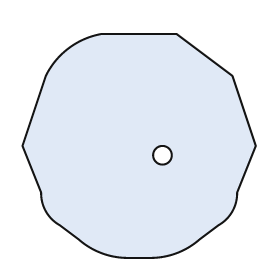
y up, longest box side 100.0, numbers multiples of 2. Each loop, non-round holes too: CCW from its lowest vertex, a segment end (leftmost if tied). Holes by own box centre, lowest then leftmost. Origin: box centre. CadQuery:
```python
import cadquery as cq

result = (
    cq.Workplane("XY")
    .moveTo(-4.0, -48.0)
    .lineTo(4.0, -48.0)
    .threePointArc((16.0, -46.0), (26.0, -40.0))
    .lineTo(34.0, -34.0)
    .threePointArc((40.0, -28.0), (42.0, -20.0))
    .lineTo(50.0, 0.0)
    .lineTo(40.0, 30.0)
    .lineTo(16.0, 48.0)
    .lineTo(-16.0, 48.0)
    .threePointArc((-30.0, 42.0), (-40.0, 30.0))
    .lineTo(-50.0, 0.0)
    .lineTo(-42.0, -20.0)
    .threePointArc((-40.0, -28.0), (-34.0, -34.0))
    .lineTo(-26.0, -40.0)
    .threePointArc((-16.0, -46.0), (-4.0, -48.0))
    .close()
    .moveTo(10.0, -4.0)
    .circle(4.0)
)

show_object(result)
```